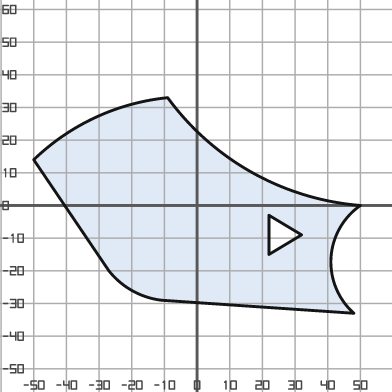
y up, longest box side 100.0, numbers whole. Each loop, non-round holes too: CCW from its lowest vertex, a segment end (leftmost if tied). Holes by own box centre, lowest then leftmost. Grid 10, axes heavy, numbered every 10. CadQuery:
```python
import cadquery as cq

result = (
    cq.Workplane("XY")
    .moveTo(48.0, -33.0)
    .threePointArc((41.0, -16.0), (50.0, 0.0))
    .threePointArc((17.0, 10.0), (-9.0, 33.0))
    .threePointArc((-31.0, 27.0), (-50.0, 14.0))
    .lineTo(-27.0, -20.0)
    .threePointArc((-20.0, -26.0), (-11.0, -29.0))
    .close()
    .moveTo(22.0, -15.0)
    .lineTo(32.0, -9.0)
    .lineTo(22.0, -3.0)
    .close()
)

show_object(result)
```